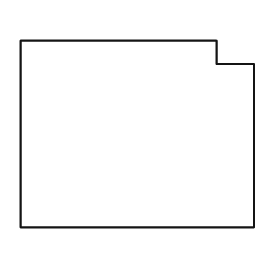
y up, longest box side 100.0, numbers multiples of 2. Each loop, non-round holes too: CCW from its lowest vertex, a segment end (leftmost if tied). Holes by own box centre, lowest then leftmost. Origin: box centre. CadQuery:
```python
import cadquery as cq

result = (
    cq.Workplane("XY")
    .moveTo(-50.0, -40.0)
    .lineTo(50.0, -40.0)
    .lineTo(50.0, 30.0)
    .lineTo(34.0, 30.0)
    .lineTo(34.0, 40.0)
    .lineTo(-50.0, 40.0)
    .close()
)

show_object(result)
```